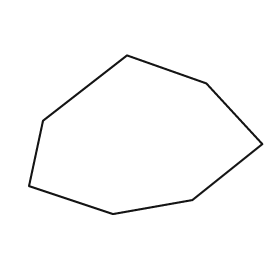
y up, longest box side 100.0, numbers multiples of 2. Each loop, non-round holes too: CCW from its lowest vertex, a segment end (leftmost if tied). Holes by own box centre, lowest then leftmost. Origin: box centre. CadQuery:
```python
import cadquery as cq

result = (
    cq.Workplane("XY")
    .moveTo(-14.0, -34.0)
    .lineTo(20.0, -28.0)
    .lineTo(50.0, -4.0)
    .lineTo(26.0, 22.0)
    .lineTo(-8.0, 34.0)
    .lineTo(-44.0, 6.0)
    .lineTo(-50.0, -22.0)
    .close()
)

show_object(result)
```